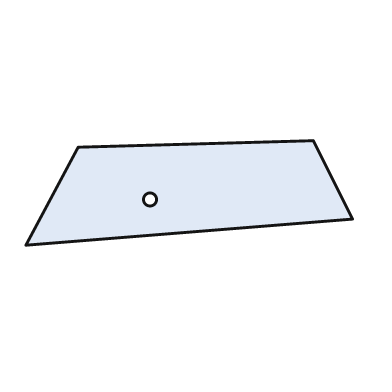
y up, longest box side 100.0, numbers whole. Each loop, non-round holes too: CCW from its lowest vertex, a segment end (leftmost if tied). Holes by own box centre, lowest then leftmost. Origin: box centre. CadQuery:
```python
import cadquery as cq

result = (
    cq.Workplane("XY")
    .moveTo(-50.0, -16.0)
    .lineTo(50.0, -8.0)
    .lineTo(38.0, 16.0)
    .lineTo(-34.0, 14.0)
    .close()
    .moveTo(-12.0, -2.0)
    .circle(2.0)
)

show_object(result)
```